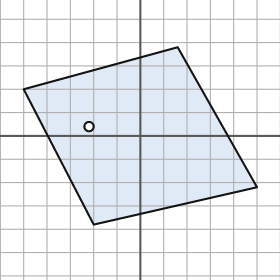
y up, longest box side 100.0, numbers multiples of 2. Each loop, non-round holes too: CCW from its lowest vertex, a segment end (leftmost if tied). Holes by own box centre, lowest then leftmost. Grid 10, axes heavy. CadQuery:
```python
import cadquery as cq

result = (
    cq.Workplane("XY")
    .moveTo(-20.0, -38.0)
    .lineTo(50.0, -22.0)
    .lineTo(16.0, 38.0)
    .lineTo(-50.0, 20.0)
    .close()
    .moveTo(-22.0, 4.0)
    .circle(2.0)
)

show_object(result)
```